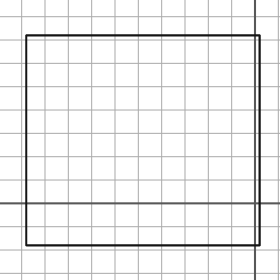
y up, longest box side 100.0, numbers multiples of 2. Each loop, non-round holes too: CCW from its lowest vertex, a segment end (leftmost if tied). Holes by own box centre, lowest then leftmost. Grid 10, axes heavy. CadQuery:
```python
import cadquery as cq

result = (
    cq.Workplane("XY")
    .moveTo(-98.0, -18.0)
    .lineTo(2.0, -18.0)
    .lineTo(2.0, 72.0)
    .lineTo(-98.0, 72.0)
    .close()
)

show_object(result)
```